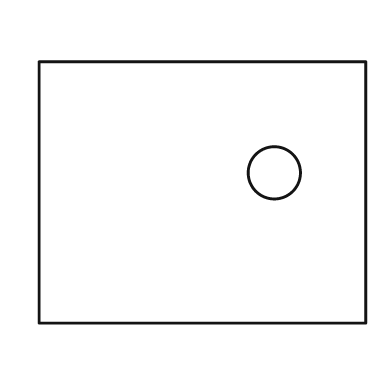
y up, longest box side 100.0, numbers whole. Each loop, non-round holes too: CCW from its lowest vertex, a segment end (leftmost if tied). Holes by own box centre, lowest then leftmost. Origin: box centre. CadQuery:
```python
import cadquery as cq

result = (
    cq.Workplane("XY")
    .moveTo(-50.0, -40.0)
    .lineTo(50.0, -40.0)
    .lineTo(50.0, 40.0)
    .lineTo(-50.0, 40.0)
    .close()
    .moveTo(22.0, 6.0)
    .circle(8.0)
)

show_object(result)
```